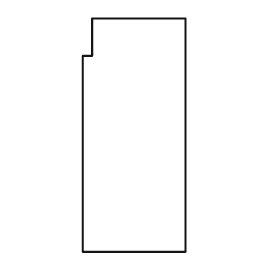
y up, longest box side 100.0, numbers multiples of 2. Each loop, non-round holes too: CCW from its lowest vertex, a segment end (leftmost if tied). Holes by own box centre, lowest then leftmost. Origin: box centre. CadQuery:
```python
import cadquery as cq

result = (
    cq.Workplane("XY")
    .moveTo(-22.0, -50.0)
    .lineTo(22.0, -50.0)
    .lineTo(22.0, 50.0)
    .lineTo(-18.0, 50.0)
    .lineTo(-18.0, 34.0)
    .lineTo(-22.0, 34.0)
    .close()
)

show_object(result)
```